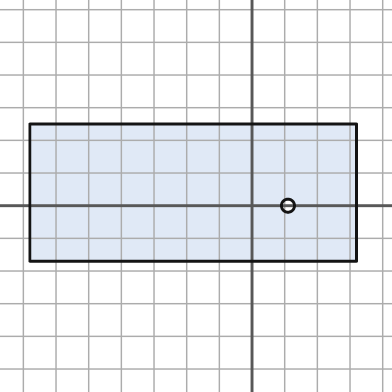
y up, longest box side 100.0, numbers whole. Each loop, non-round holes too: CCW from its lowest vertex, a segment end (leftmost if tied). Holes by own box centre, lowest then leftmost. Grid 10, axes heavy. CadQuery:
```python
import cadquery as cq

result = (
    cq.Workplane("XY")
    .moveTo(-68.0, -17.0)
    .lineTo(32.0, -17.0)
    .lineTo(32.0, 25.0)
    .lineTo(-68.0, 25.0)
    .close()
    .moveTo(11.0, 0.0)
    .circle(2.0)
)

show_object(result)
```